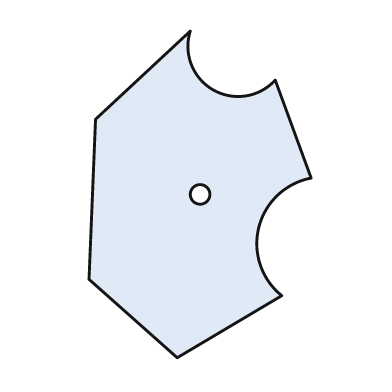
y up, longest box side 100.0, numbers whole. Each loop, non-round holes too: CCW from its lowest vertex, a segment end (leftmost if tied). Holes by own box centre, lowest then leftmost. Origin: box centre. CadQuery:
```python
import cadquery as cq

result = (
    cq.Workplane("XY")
    .moveTo(-7.0, -50.0)
    .lineTo(25.0, -31.0)
    .threePointArc((18.0, -10.0), (34.0, 5.0))
    .lineTo(23.0, 35.0)
    .threePointArc((4.0, 32.0), (-3.0, 50.0))
    .lineTo(-32.0, 23.0)
    .lineTo(-34.0, -26.0)
    .close()
    .moveTo(0.0, 0.0)
    .circle(3.0)
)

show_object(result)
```